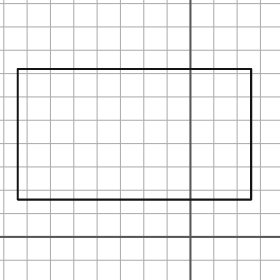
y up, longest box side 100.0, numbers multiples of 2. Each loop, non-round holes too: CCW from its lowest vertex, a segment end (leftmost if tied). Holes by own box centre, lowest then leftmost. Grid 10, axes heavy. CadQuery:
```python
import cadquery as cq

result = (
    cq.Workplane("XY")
    .moveTo(-74.0, 16.0)
    .lineTo(26.0, 16.0)
    .lineTo(26.0, 72.0)
    .lineTo(-74.0, 72.0)
    .close()
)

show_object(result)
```